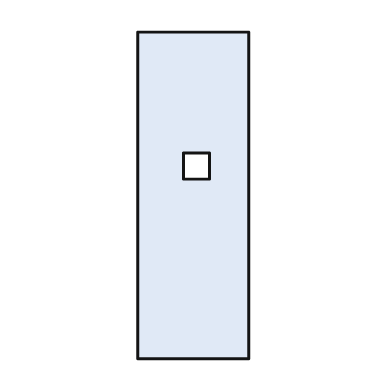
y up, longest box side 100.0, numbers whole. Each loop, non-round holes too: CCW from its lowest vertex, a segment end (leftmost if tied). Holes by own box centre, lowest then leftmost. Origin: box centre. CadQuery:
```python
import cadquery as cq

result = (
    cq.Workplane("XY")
    .moveTo(-17.0, -50.0)
    .lineTo(17.0, -50.0)
    .lineTo(17.0, 50.0)
    .lineTo(-17.0, 50.0)
    .close()
    .moveTo(-3.0, 5.0)
    .lineTo(5.0, 5.0)
    .lineTo(5.0, 13.0)
    .lineTo(-3.0, 13.0)
    .close()
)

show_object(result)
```